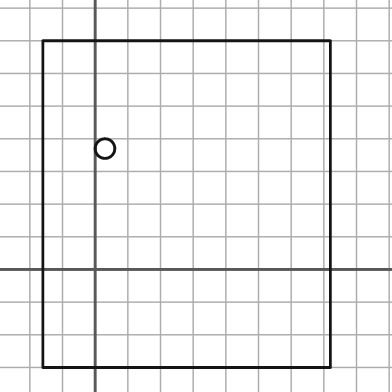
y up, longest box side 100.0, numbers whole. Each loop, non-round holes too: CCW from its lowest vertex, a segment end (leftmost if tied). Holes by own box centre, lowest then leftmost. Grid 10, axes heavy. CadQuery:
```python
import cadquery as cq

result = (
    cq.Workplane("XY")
    .moveTo(-16.0, -30.0)
    .lineTo(72.0, -30.0)
    .lineTo(72.0, 70.0)
    .lineTo(-16.0, 70.0)
    .close()
    .moveTo(3.0, 37.0)
    .circle(3.0)
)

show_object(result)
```